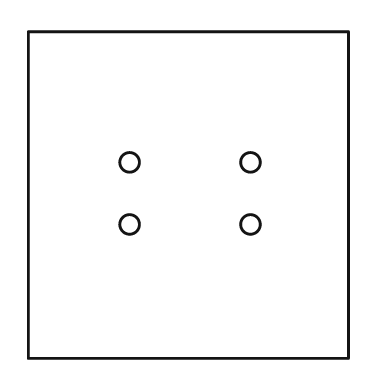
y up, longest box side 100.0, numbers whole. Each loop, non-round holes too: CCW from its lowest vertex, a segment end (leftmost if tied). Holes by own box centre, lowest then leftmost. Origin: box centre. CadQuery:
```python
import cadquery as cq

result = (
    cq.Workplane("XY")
    .moveTo(-49.0, -50.0)
    .lineTo(49.0, -50.0)
    .lineTo(49.0, 50.0)
    .lineTo(-49.0, 50.0)
    .close()
    .moveTo(-18.0, -9.0)
    .circle(3.0)
    .moveTo(19.0, -9.0)
    .circle(3.0)
    .moveTo(-18.0, 10.0)
    .circle(3.0)
    .moveTo(19.0, 10.0)
    .circle(3.0)
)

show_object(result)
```